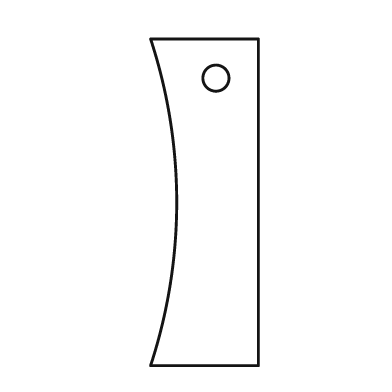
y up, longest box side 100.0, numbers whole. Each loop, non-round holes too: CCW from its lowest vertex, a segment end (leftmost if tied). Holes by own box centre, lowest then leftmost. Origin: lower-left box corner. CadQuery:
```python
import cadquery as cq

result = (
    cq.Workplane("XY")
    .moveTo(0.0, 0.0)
    .lineTo(33.0, 0.0)
    .lineTo(33.0, 100.0)
    .lineTo(0.0, 100.0)
    .threePointArc((8.0, 50.0), (0.0, 0.0))
    .close()
    .moveTo(20.0, 88.0)
    .circle(4.0)
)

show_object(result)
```